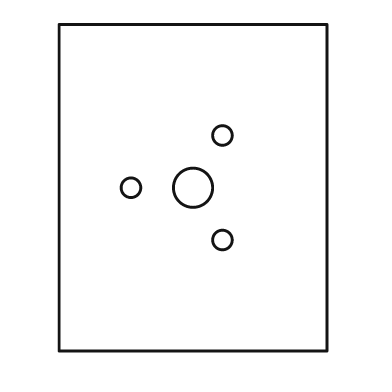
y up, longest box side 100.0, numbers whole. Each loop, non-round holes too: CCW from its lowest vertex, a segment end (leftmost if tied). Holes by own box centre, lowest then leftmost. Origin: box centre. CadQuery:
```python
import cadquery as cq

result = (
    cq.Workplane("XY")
    .moveTo(-41.0, -50.0)
    .lineTo(41.0, -50.0)
    .lineTo(41.0, 50.0)
    .lineTo(-41.0, 50.0)
    .close()
    .moveTo(9.0, -16.0)
    .circle(3.0)
    .moveTo(-19.0, 0.0)
    .circle(3.0)
    .moveTo(0.0, 0.0)
    .circle(6.0)
    .moveTo(9.0, 16.0)
    .circle(3.0)
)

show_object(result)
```